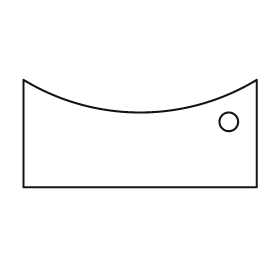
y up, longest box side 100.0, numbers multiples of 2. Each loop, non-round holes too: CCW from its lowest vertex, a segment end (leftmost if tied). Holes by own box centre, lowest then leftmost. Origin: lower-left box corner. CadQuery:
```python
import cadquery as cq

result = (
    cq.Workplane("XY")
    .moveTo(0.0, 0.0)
    .lineTo(100.0, 0.0)
    .lineTo(100.0, 46.0)
    .threePointArc((50.0, 32.0), (0.0, 46.0))
    .close()
    .moveTo(88.0, 28.0)
    .circle(4.0)
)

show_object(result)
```